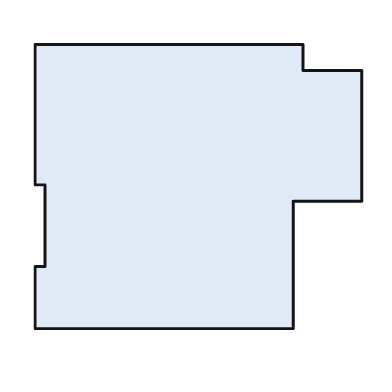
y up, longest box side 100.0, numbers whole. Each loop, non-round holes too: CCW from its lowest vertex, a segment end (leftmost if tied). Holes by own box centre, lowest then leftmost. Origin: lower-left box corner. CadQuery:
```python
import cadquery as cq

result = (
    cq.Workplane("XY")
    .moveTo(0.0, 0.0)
    .lineTo(79.0, 0.0)
    .lineTo(79.0, 39.0)
    .lineTo(100.0, 39.0)
    .lineTo(100.0, 79.0)
    .lineTo(82.0, 79.0)
    .lineTo(82.0, 87.0)
    .lineTo(0.0, 87.0)
    .lineTo(0.0, 44.0)
    .lineTo(3.0, 44.0)
    .lineTo(3.0, 19.0)
    .lineTo(0.0, 19.0)
    .close()
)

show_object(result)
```